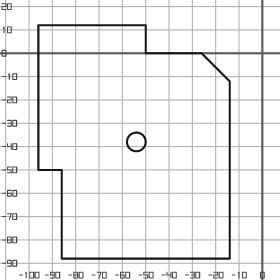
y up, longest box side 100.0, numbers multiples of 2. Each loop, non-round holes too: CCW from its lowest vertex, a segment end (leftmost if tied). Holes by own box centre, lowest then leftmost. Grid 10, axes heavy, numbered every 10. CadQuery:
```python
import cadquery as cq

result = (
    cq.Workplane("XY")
    .moveTo(-86.0, -88.0)
    .lineTo(-14.0, -88.0)
    .lineTo(-14.0, -12.0)
    .lineTo(-26.0, 0.0)
    .lineTo(-50.0, 0.0)
    .lineTo(-50.0, 12.0)
    .lineTo(-96.0, 12.0)
    .lineTo(-96.0, -50.0)
    .lineTo(-86.0, -50.0)
    .close()
    .moveTo(-54.0, -38.0)
    .circle(4.0)
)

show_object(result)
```